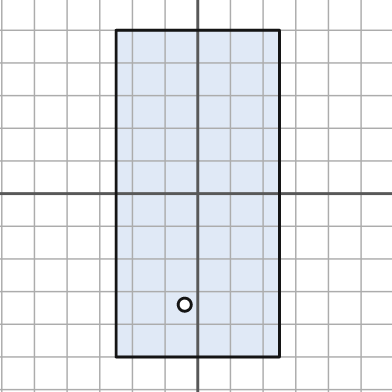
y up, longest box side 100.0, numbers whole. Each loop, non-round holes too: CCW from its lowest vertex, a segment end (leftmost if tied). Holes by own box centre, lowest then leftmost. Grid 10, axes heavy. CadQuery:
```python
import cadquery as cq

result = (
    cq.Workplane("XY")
    .moveTo(-25.0, -50.0)
    .lineTo(25.0, -50.0)
    .lineTo(25.0, 50.0)
    .lineTo(-25.0, 50.0)
    .close()
    .moveTo(-4.0, -34.0)
    .circle(2.0)
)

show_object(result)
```